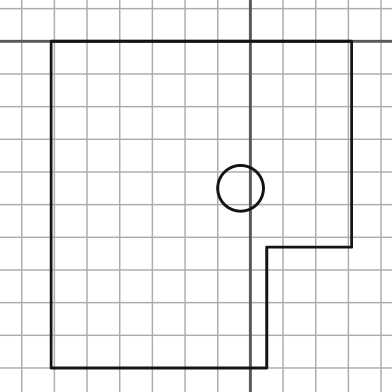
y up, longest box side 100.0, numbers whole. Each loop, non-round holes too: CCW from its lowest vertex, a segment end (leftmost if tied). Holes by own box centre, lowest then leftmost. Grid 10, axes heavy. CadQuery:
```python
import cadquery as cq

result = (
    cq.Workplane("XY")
    .moveTo(-61.0, -100.0)
    .lineTo(5.0, -100.0)
    .lineTo(5.0, -63.0)
    .lineTo(31.0, -63.0)
    .lineTo(31.0, 0.0)
    .lineTo(-61.0, 0.0)
    .close()
    .moveTo(-3.0, -45.0)
    .circle(7.0)
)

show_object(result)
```